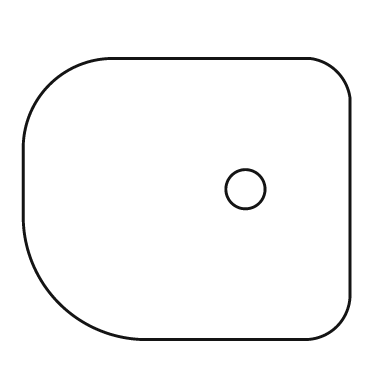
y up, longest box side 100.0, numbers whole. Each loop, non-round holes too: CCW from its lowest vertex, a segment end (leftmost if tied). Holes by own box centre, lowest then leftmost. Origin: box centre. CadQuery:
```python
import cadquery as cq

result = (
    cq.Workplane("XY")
    .moveTo(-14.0, -43.0)
    .lineTo(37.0, -43.0)
    .threePointArc((46.0, -39.0), (50.0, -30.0))
    .lineTo(50.0, 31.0)
    .threePointArc((46.0, 39.0), (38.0, 43.0))
    .lineTo(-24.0, 43.0)
    .threePointArc((-42.0, 35.0), (-50.0, 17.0))
    .lineTo(-50.0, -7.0)
    .threePointArc((-39.0, -32.0), (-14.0, -43.0))
    .close()
    .moveTo(18.0, 3.0)
    .circle(6.0)
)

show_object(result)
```